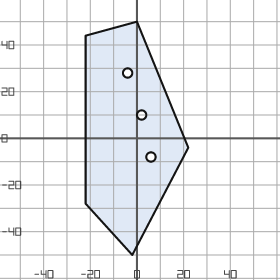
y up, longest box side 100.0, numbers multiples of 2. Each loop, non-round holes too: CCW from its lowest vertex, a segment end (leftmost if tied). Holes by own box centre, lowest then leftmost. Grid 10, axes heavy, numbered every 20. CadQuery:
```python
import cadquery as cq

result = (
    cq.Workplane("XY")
    .moveTo(-2.0, -50.0)
    .lineTo(22.0, -4.0)
    .lineTo(0.0, 50.0)
    .lineTo(-22.0, 44.0)
    .lineTo(-22.0, -28.0)
    .close()
    .moveTo(6.0, -8.0)
    .circle(2.0)
    .moveTo(2.0, 10.0)
    .circle(2.0)
    .moveTo(-4.0, 28.0)
    .circle(2.0)
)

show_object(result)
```